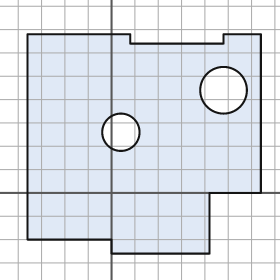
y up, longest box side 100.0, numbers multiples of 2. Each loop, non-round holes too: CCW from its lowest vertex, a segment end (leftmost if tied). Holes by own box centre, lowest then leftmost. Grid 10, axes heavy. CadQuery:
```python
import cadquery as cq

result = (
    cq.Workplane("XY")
    .moveTo(0.0, -26.0)
    .lineTo(42.0, -26.0)
    .lineTo(42.0, 0.0)
    .lineTo(64.0, 0.0)
    .lineTo(64.0, 68.0)
    .lineTo(48.0, 68.0)
    .lineTo(48.0, 64.0)
    .lineTo(8.0, 64.0)
    .lineTo(8.0, 68.0)
    .lineTo(-36.0, 68.0)
    .lineTo(-36.0, -20.0)
    .lineTo(0.0, -20.0)
    .close()
    .moveTo(4.0, 26.0)
    .circle(8.0)
    .moveTo(48.0, 44.0)
    .circle(10.0)
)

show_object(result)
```